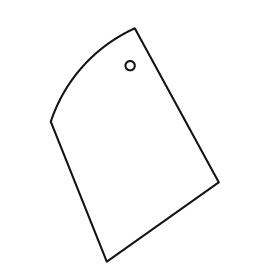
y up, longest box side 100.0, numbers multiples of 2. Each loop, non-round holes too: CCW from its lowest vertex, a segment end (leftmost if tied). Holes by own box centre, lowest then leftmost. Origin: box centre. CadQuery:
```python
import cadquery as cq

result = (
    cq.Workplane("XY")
    .moveTo(-12.0, -50.0)
    .lineTo(36.0, -16.0)
    .lineTo(0.0, 50.0)
    .threePointArc((-22.0, 34.0), (-36.0, 10.0))
    .close()
    .moveTo(-2.0, 34.0)
    .circle(2.0)
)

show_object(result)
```